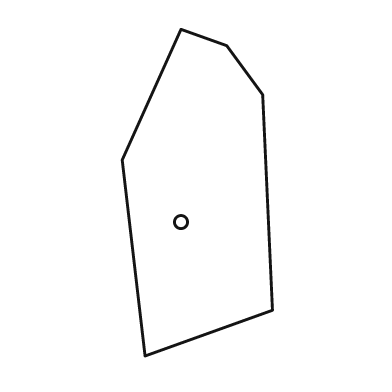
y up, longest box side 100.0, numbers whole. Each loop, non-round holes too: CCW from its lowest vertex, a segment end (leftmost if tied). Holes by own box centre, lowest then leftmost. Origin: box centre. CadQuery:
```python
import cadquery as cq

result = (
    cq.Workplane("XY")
    .moveTo(-16.0, -50.0)
    .lineTo(23.0, -36.0)
    .lineTo(20.0, 30.0)
    .lineTo(9.0, 45.0)
    .lineTo(-5.0, 50.0)
    .lineTo(-23.0, 10.0)
    .close()
    .moveTo(-5.0, -9.0)
    .circle(2.0)
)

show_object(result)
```